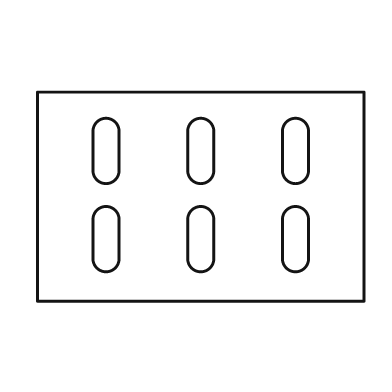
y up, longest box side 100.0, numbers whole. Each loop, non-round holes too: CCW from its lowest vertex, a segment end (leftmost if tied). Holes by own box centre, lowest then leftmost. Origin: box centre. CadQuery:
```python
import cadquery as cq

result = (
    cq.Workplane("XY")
    .moveTo(-50.0, -32.0)
    .lineTo(50.0, -32.0)
    .lineTo(50.0, 32.0)
    .lineTo(-50.0, 32.0)
    .close()
    .moveTo(-33.0, -19.0)
    .threePointArc((-29.0, -23.0), (-25.0, -19.0))
    .lineTo(-25.0, -7.0)
    .threePointArc((-29.0, -3.0), (-33.0, -7.0))
    .close()
    .moveTo(-4.0, -19.0)
    .threePointArc((0.0, -23.0), (4.0, -19.0))
    .lineTo(4.0, -7.0)
    .threePointArc((0.0, -3.0), (-4.0, -7.0))
    .close()
    .moveTo(25.0, -19.0)
    .threePointArc((29.0, -23.0), (33.0, -19.0))
    .lineTo(33.0, -7.0)
    .threePointArc((29.0, -3.0), (25.0, -7.0))
    .close()
    .moveTo(-33.0, 8.0)
    .threePointArc((-29.0, 4.0), (-25.0, 8.0))
    .lineTo(-25.0, 20.0)
    .threePointArc((-29.0, 24.0), (-33.0, 20.0))
    .close()
    .moveTo(-4.0, 8.0)
    .threePointArc((0.0, 4.0), (4.0, 8.0))
    .lineTo(4.0, 20.0)
    .threePointArc((0.0, 24.0), (-4.0, 20.0))
    .close()
    .moveTo(25.0, 8.0)
    .threePointArc((29.0, 4.0), (33.0, 8.0))
    .lineTo(33.0, 20.0)
    .threePointArc((29.0, 24.0), (25.0, 20.0))
    .close()
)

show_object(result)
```